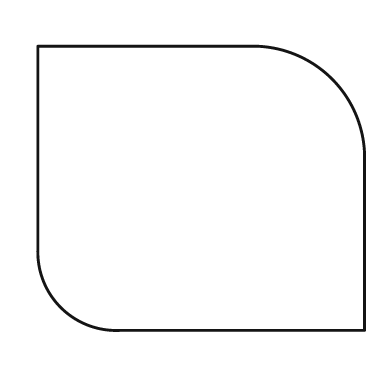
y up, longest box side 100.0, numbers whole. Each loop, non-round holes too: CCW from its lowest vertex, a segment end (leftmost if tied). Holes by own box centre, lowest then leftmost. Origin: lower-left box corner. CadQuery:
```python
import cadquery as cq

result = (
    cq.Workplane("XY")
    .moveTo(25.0, 0.0)
    .lineTo(100.0, 0.0)
    .lineTo(100.0, 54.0)
    .threePointArc((90.0, 77.0), (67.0, 87.0))
    .lineTo(0.0, 87.0)
    .lineTo(0.0, 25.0)
    .threePointArc((7.0, 7.0), (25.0, 0.0))
    .close()
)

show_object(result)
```